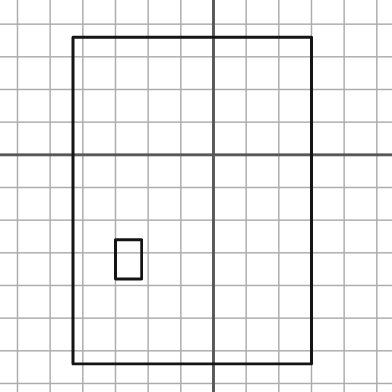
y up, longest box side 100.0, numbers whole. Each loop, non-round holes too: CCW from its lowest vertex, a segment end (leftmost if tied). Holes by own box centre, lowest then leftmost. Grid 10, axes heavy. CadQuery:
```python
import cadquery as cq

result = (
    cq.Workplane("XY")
    .moveTo(-43.0, -64.0)
    .lineTo(30.0, -64.0)
    .lineTo(30.0, 36.0)
    .lineTo(-43.0, 36.0)
    .close()
    .moveTo(-30.0, -38.0)
    .lineTo(-22.0, -38.0)
    .lineTo(-22.0, -26.0)
    .lineTo(-30.0, -26.0)
    .close()
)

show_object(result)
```